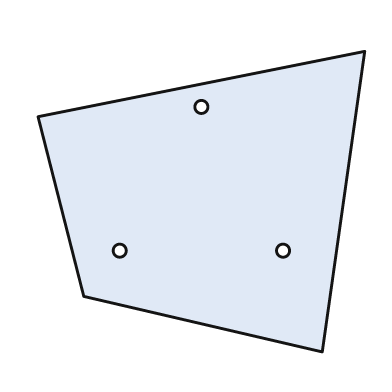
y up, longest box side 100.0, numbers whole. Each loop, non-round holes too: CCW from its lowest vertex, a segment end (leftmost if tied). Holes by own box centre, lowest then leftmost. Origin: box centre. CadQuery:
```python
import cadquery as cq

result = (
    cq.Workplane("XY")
    .moveTo(37.0, -46.0)
    .lineTo(50.0, 46.0)
    .lineTo(-50.0, 26.0)
    .lineTo(-36.0, -29.0)
    .close()
    .moveTo(-25.0, -15.0)
    .circle(2.0)
    .moveTo(25.0, -15.0)
    .circle(2.0)
    .moveTo(0.0, 29.0)
    .circle(2.0)
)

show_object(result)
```